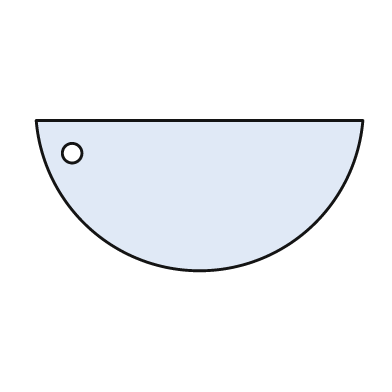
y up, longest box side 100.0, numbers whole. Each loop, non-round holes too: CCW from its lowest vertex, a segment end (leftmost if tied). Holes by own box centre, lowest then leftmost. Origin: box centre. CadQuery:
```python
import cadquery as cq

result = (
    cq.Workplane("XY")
    .moveTo(-50.0, 23.0)
    .threePointArc((0.0, -23.0), (50.0, 23.0))
    .close()
    .moveTo(-39.0, 13.0)
    .circle(3.0)
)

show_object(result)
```